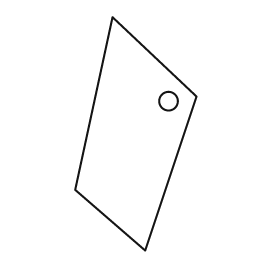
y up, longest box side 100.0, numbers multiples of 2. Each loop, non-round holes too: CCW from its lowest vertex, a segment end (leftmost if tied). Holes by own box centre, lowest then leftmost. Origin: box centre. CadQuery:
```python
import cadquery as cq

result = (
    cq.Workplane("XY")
    .moveTo(4.0, -50.0)
    .lineTo(26.0, 16.0)
    .lineTo(-10.0, 50.0)
    .lineTo(-26.0, -24.0)
    .close()
    .moveTo(14.0, 14.0)
    .circle(4.0)
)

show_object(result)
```